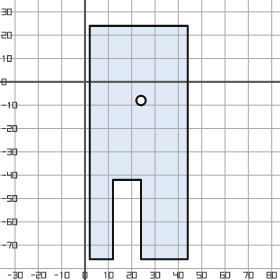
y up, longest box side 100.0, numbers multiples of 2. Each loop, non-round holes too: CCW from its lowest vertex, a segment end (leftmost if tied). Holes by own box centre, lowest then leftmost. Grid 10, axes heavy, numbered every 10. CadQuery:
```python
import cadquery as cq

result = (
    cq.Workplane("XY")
    .moveTo(2.0, -76.0)
    .lineTo(12.0, -76.0)
    .lineTo(12.0, -42.0)
    .lineTo(24.0, -42.0)
    .lineTo(24.0, -76.0)
    .lineTo(44.0, -76.0)
    .lineTo(44.0, 24.0)
    .lineTo(2.0, 24.0)
    .close()
    .moveTo(24.0, -8.0)
    .circle(2.0)
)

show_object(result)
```